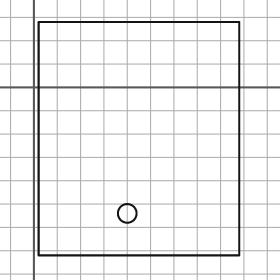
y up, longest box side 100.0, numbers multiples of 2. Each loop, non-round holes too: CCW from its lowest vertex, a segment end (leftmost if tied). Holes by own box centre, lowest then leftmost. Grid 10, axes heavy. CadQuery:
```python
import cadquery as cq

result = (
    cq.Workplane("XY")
    .moveTo(2.0, -72.0)
    .lineTo(88.0, -72.0)
    .lineTo(88.0, 28.0)
    .lineTo(2.0, 28.0)
    .close()
    .moveTo(40.0, -54.0)
    .circle(4.0)
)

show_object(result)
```